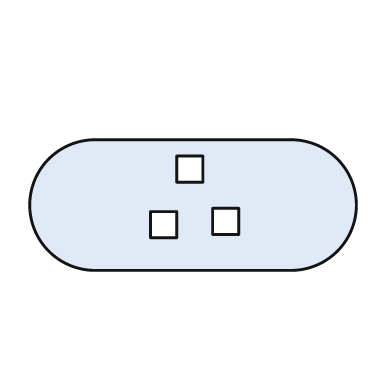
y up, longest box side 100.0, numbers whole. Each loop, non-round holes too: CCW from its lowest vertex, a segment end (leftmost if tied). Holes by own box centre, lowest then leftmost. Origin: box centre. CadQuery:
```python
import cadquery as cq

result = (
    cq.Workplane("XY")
    .moveTo(-30.0, -20.0)
    .lineTo(30.0, -20.0)
    .threePointArc((50.0, 0.0), (30.0, 20.0))
    .lineTo(-30.0, 20.0)
    .threePointArc((-50.0, 0.0), (-30.0, -20.0))
    .close()
    .moveTo(-13.0, -10.0)
    .lineTo(-5.0, -10.0)
    .lineTo(-5.0, -2.0)
    .lineTo(-13.0, -2.0)
    .close()
    .moveTo(6.0, -9.0)
    .lineTo(14.0, -9.0)
    .lineTo(14.0, -1.0)
    .lineTo(6.0, -1.0)
    .close()
    .moveTo(-5.0, 7.0)
    .lineTo(3.0, 7.0)
    .lineTo(3.0, 15.0)
    .lineTo(-5.0, 15.0)
    .close()
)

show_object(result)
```